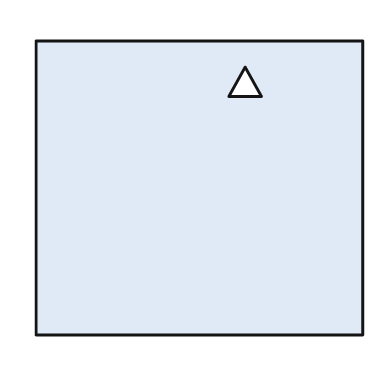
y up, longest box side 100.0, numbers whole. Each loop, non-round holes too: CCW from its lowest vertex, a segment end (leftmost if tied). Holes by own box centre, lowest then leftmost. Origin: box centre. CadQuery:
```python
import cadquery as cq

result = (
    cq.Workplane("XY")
    .moveTo(-50.0, -45.0)
    .lineTo(50.0, -45.0)
    .lineTo(50.0, 45.0)
    .lineTo(-50.0, 45.0)
    .close()
    .moveTo(9.0, 28.0)
    .lineTo(19.0, 28.0)
    .lineTo(14.0, 37.0)
    .close()
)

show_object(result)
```